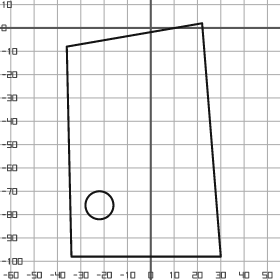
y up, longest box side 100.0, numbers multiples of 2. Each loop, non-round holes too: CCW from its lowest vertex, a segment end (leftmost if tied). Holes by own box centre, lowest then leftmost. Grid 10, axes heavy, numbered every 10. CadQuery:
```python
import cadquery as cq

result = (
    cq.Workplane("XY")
    .moveTo(-34.0, -98.0)
    .lineTo(30.0, -98.0)
    .lineTo(22.0, 2.0)
    .lineTo(-36.0, -8.0)
    .close()
    .moveTo(-22.0, -76.0)
    .circle(6.0)
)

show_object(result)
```